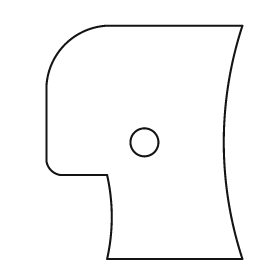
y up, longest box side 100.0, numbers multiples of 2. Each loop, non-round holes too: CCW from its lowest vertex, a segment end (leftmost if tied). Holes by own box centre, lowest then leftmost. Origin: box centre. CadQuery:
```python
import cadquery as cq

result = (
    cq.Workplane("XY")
    .moveTo(-16.0, -50.0)
    .lineTo(42.0, -50.0)
    .threePointArc((34.0, 0.0), (42.0, 50.0))
    .lineTo(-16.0, 50.0)
    .threePointArc((-34.0, 42.0), (-42.0, 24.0))
    .lineTo(-42.0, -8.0)
    .threePointArc((-40.0, -12.0), (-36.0, -14.0))
    .lineTo(-16.0, -14.0)
    .threePointArc((-14.0, -32.0), (-16.0, -50.0))
    .close()
    .moveTo(0.0, 0.0)
    .circle(6.0)
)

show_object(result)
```